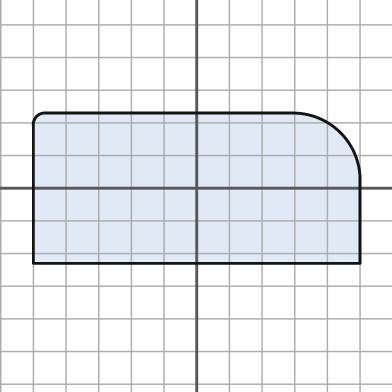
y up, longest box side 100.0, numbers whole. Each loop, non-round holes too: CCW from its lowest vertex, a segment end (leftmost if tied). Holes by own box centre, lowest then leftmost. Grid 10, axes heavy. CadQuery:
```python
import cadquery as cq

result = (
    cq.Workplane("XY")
    .moveTo(-50.0, -23.0)
    .lineTo(50.0, -23.0)
    .lineTo(50.0, 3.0)
    .threePointArc((44.0, 17.0), (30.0, 23.0))
    .lineTo(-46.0, 23.0)
    .threePointArc((-49.0, 22.0), (-50.0, 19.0))
    .close()
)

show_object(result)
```